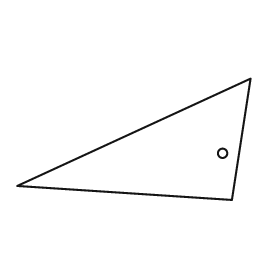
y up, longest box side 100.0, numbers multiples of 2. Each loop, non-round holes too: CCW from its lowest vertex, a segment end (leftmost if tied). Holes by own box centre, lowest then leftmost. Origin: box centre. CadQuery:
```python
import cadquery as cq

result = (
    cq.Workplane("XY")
    .moveTo(42.0, -26.0)
    .lineTo(50.0, 26.0)
    .lineTo(-50.0, -20.0)
    .close()
    .moveTo(38.0, -6.0)
    .circle(2.0)
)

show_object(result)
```